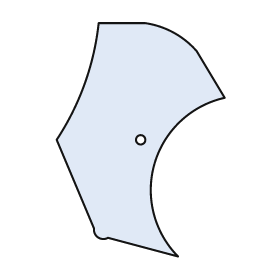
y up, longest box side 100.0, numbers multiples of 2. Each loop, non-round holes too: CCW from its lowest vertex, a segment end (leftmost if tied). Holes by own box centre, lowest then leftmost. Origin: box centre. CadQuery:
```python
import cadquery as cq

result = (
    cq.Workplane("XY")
    .moveTo(16.0, -50.0)
    .threePointArc((6.0, -10.0), (36.0, 18.0))
    .lineTo(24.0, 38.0)
    .threePointArc((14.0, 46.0), (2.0, 50.0))
    .lineTo(-18.0, 50.0)
    .threePointArc((-24.0, 24.0), (-36.0, 0.0))
    .lineTo(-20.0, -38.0)
    .threePointArc((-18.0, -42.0), (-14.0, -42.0))
    .close()
    .moveTo(0.0, 0.0)
    .circle(2.0)
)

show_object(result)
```